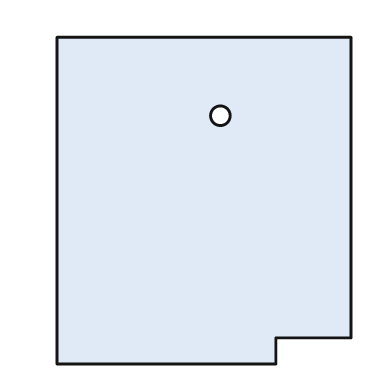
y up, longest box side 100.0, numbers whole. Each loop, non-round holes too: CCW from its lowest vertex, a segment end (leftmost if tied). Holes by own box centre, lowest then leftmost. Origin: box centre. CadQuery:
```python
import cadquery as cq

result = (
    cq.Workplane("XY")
    .moveTo(-45.0, -50.0)
    .lineTo(22.0, -50.0)
    .lineTo(22.0, -42.0)
    .lineTo(45.0, -42.0)
    .lineTo(45.0, 50.0)
    .lineTo(-45.0, 50.0)
    .close()
    .moveTo(5.0, 26.0)
    .circle(3.0)
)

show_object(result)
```